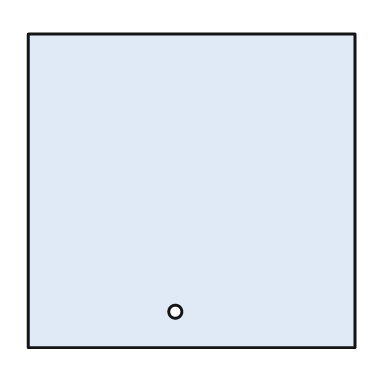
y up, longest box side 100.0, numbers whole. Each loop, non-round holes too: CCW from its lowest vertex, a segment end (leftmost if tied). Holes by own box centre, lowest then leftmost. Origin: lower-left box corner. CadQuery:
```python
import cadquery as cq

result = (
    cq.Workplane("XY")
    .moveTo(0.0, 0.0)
    .lineTo(100.0, 0.0)
    .lineTo(100.0, 96.0)
    .lineTo(0.0, 96.0)
    .close()
    .moveTo(45.0, 11.0)
    .circle(2.0)
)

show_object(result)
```